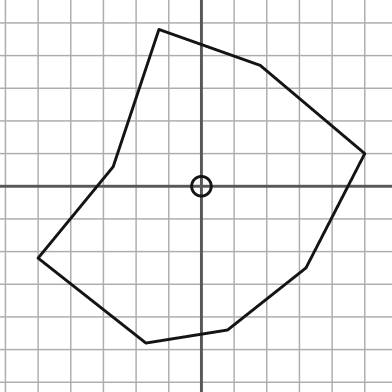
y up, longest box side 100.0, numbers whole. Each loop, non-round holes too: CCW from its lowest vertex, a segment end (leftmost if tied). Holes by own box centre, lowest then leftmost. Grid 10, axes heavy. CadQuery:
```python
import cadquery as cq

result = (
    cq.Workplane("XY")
    .moveTo(-17.0, -48.0)
    .lineTo(8.0, -44.0)
    .lineTo(32.0, -25.0)
    .lineTo(50.0, 10.0)
    .lineTo(18.0, 37.0)
    .lineTo(-13.0, 48.0)
    .lineTo(-27.0, 6.0)
    .lineTo(-50.0, -22.0)
    .close()
    .moveTo(0.0, 0.0)
    .circle(3.0)
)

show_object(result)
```